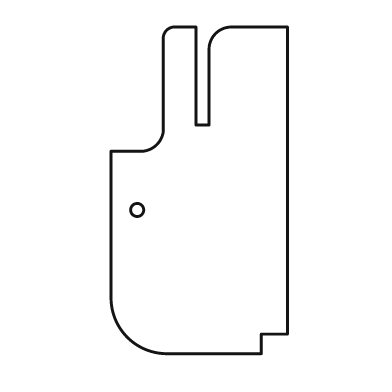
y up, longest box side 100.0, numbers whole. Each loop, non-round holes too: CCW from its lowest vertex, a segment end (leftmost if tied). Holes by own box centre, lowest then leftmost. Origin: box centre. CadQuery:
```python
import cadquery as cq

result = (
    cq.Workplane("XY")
    .moveTo(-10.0, -50.0)
    .lineTo(19.0, -50.0)
    .lineTo(19.0, -44.0)
    .lineTo(27.0, -44.0)
    .lineTo(27.0, 50.0)
    .lineTo(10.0, 50.0)
    .threePointArc((5.0, 48.0), (3.0, 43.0))
    .lineTo(3.0, 20.0)
    .lineTo(-1.0, 20.0)
    .lineTo(-1.0, 50.0)
    .lineTo(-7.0, 50.0)
    .threePointArc((-10.0, 49.0), (-11.0, 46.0))
    .lineTo(-11.0, 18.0)
    .threePointArc((-13.0, 14.0), (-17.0, 12.0))
    .lineTo(-27.0, 12.0)
    .lineTo(-27.0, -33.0)
    .threePointArc((-22.0, -45.0), (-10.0, -50.0))
    .close()
    .moveTo(-19.0, -6.0)
    .circle(2.0)
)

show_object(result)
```